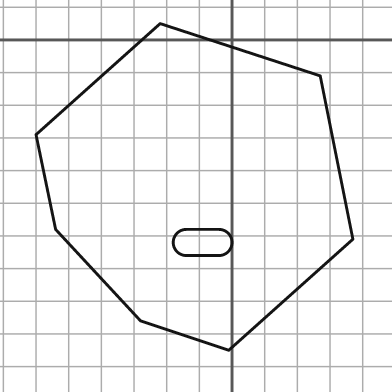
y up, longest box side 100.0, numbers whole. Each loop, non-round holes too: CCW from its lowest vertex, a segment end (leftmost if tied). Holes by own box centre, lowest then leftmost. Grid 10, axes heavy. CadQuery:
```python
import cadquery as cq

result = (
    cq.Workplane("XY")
    .moveTo(-1.0, -95.0)
    .lineTo(37.0, -61.0)
    .lineTo(27.0, -11.0)
    .lineTo(-22.0, 5.0)
    .lineTo(-60.0, -29.0)
    .lineTo(-54.0, -58.0)
    .lineTo(-28.0, -86.0)
    .close()
    .moveTo(-14.0, -66.0)
    .lineTo(-4.0, -66.0)
    .threePointArc((0.0, -62.0), (-4.0, -58.0))
    .lineTo(-14.0, -58.0)
    .threePointArc((-18.0, -62.0), (-14.0, -66.0))
    .close()
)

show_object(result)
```